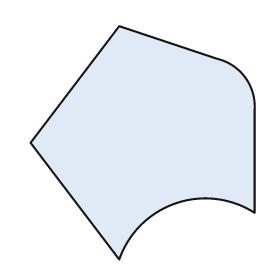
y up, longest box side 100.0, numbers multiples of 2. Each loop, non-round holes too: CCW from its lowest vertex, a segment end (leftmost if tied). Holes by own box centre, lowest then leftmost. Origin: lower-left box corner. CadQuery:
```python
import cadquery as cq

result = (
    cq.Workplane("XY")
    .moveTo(38.0, 0.0)
    .threePointArc((62.0, 24.0), (96.0, 20.0))
    .lineTo(96.0, 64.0)
    .threePointArc((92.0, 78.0), (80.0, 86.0))
    .lineTo(38.0, 100.0)
    .lineTo(0.0, 50.0)
    .close()
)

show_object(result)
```